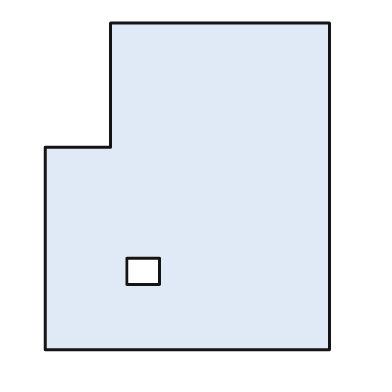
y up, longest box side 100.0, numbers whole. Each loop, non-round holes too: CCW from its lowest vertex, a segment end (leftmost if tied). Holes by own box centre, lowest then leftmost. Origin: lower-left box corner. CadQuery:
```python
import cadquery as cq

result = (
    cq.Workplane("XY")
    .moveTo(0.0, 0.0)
    .lineTo(87.0, 0.0)
    .lineTo(87.0, 100.0)
    .lineTo(20.0, 100.0)
    .lineTo(20.0, 62.0)
    .lineTo(0.0, 62.0)
    .close()
    .moveTo(25.0, 20.0)
    .lineTo(35.0, 20.0)
    .lineTo(35.0, 28.0)
    .lineTo(25.0, 28.0)
    .close()
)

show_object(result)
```